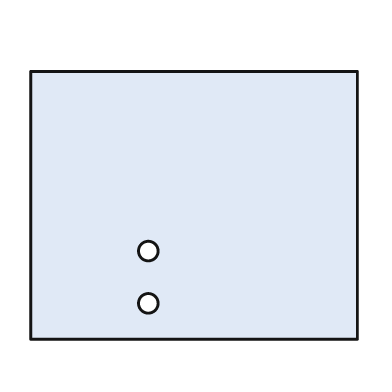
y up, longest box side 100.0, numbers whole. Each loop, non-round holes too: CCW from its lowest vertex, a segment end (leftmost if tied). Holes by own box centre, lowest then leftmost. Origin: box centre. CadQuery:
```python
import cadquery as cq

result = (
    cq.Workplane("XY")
    .moveTo(-50.0, -41.0)
    .lineTo(50.0, -41.0)
    .lineTo(50.0, 41.0)
    .lineTo(-50.0, 41.0)
    .close()
    .moveTo(-14.0, -30.0)
    .circle(3.0)
    .moveTo(-14.0, -14.0)
    .circle(3.0)
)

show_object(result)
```